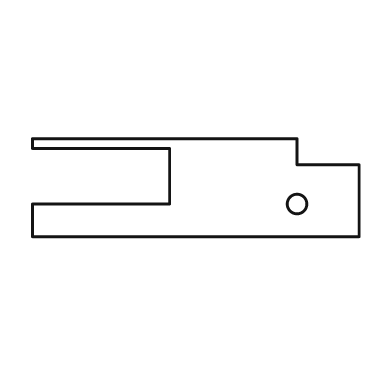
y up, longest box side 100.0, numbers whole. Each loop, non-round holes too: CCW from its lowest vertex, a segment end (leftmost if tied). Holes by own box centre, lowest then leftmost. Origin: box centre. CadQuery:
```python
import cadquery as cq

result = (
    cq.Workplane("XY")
    .moveTo(-50.0, -15.0)
    .lineTo(50.0, -15.0)
    .lineTo(50.0, 7.0)
    .lineTo(31.0, 7.0)
    .lineTo(31.0, 15.0)
    .lineTo(-50.0, 15.0)
    .lineTo(-50.0, 12.0)
    .lineTo(-8.0, 12.0)
    .lineTo(-8.0, -5.0)
    .lineTo(-50.0, -5.0)
    .close()
    .moveTo(31.0, -5.0)
    .circle(3.0)
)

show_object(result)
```